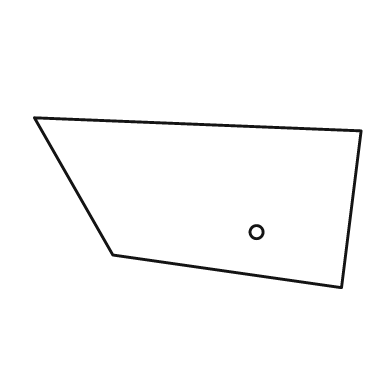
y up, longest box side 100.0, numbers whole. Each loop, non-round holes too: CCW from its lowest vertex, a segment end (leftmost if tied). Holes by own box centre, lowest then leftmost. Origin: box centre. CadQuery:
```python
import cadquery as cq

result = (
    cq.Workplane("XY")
    .moveTo(44.0, -26.0)
    .lineTo(50.0, 22.0)
    .lineTo(-50.0, 26.0)
    .lineTo(-26.0, -16.0)
    .close()
    .moveTo(18.0, -9.0)
    .circle(2.0)
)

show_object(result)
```